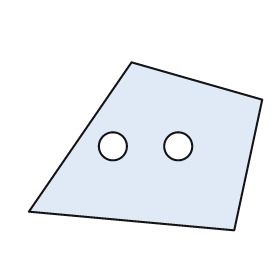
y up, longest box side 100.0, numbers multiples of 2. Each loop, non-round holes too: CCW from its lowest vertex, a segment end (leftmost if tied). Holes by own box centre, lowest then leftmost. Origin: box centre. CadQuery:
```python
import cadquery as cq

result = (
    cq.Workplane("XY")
    .moveTo(38.0, -36.0)
    .lineTo(50.0, 20.0)
    .lineTo(-6.0, 36.0)
    .lineTo(-50.0, -28.0)
    .close()
    .moveTo(-14.0, 0.0)
    .circle(6.0)
    .moveTo(14.0, 0.0)
    .circle(6.0)
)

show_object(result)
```